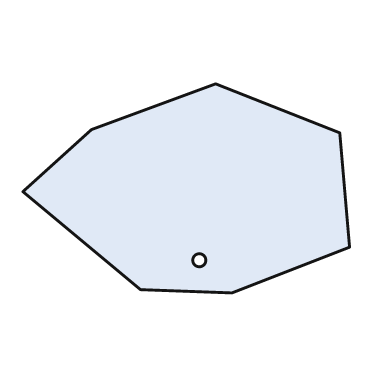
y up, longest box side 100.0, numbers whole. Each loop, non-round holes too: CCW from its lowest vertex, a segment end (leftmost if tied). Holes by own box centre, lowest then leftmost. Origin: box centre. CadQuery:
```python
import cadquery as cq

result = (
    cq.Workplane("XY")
    .moveTo(14.0, -32.0)
    .lineTo(50.0, -18.0)
    .lineTo(47.0, 17.0)
    .lineTo(9.0, 32.0)
    .lineTo(-29.0, 18.0)
    .lineTo(-50.0, -1.0)
    .lineTo(-14.0, -31.0)
    .close()
    .moveTo(4.0, -22.0)
    .circle(2.0)
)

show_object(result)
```